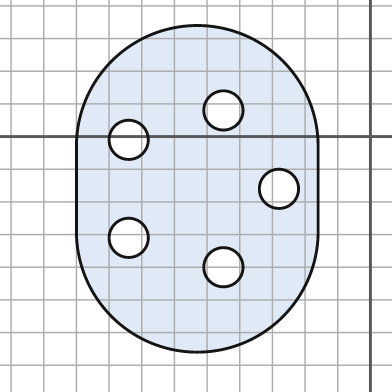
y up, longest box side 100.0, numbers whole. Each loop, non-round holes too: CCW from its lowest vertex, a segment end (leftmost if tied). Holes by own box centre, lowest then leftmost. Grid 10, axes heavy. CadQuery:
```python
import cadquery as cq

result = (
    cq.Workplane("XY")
    .moveTo(-90.0, -29.0)
    .threePointArc((-53.0, -66.0), (-16.0, -29.0))
    .lineTo(-16.0, -3.0)
    .threePointArc((-53.0, 34.0), (-90.0, -3.0))
    .close()
    .moveTo(-45.0, -40.0)
    .circle(6.0)
    .moveTo(-74.0, -31.0)
    .circle(6.0)
    .moveTo(-28.0, -16.0)
    .circle(6.0)
    .moveTo(-74.0, -1.0)
    .circle(6.0)
    .moveTo(-45.0, 8.0)
    .circle(6.0)
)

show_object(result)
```